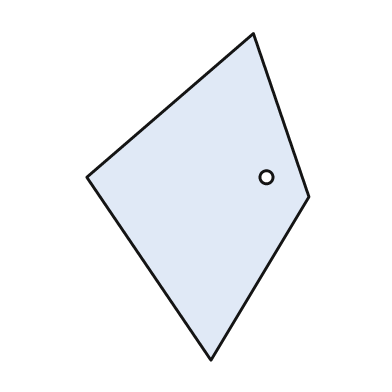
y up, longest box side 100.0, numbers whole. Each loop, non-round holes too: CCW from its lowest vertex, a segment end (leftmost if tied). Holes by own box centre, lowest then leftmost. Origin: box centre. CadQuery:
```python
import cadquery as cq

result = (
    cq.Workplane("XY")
    .moveTo(4.0, -50.0)
    .lineTo(34.0, 0.0)
    .lineTo(17.0, 50.0)
    .lineTo(-34.0, 6.0)
    .close()
    .moveTo(21.0, 6.0)
    .circle(2.0)
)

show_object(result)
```